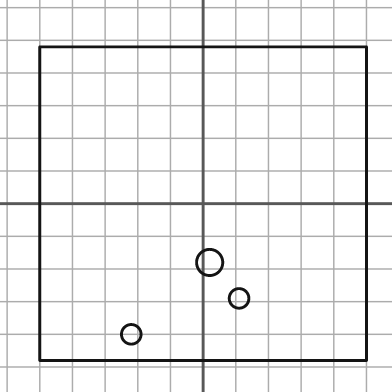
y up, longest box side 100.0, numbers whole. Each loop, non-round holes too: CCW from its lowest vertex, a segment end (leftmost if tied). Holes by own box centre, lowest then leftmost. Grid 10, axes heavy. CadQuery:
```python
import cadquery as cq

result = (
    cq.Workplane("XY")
    .moveTo(-50.0, -48.0)
    .lineTo(50.0, -48.0)
    .lineTo(50.0, 48.0)
    .lineTo(-50.0, 48.0)
    .close()
    .moveTo(-22.0, -40.0)
    .circle(3.0)
    .moveTo(11.0, -29.0)
    .circle(3.0)
    .moveTo(2.0, -18.0)
    .circle(4.0)
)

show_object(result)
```